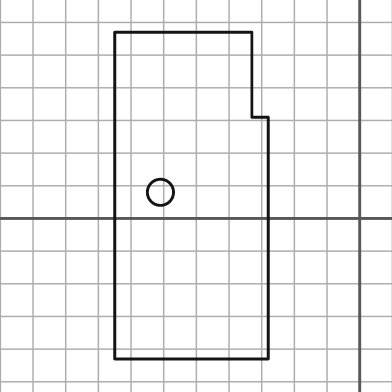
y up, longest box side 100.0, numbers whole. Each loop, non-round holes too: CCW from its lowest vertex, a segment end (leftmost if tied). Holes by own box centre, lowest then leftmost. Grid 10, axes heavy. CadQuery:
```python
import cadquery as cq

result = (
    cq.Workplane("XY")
    .moveTo(-75.0, -43.0)
    .lineTo(-28.0, -43.0)
    .lineTo(-28.0, 31.0)
    .lineTo(-33.0, 31.0)
    .lineTo(-33.0, 57.0)
    .lineTo(-75.0, 57.0)
    .close()
    .moveTo(-61.0, 8.0)
    .circle(4.0)
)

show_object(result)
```